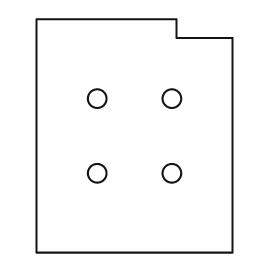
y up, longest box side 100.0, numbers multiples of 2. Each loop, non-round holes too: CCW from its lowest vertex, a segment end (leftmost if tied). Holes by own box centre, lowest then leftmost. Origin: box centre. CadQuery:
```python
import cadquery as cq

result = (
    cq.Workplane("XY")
    .moveTo(-42.0, -50.0)
    .lineTo(42.0, -50.0)
    .lineTo(42.0, 42.0)
    .lineTo(18.0, 42.0)
    .lineTo(18.0, 50.0)
    .lineTo(-42.0, 50.0)
    .close()
    .moveTo(-16.0, -16.0)
    .circle(4.0)
    .moveTo(16.0, -16.0)
    .circle(4.0)
    .moveTo(-16.0, 16.0)
    .circle(4.0)
    .moveTo(16.0, 16.0)
    .circle(4.0)
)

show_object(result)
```